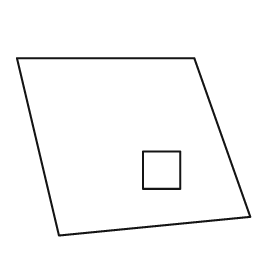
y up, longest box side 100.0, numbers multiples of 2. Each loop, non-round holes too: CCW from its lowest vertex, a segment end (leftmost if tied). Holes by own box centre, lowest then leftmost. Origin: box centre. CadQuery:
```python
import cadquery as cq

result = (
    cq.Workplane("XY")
    .moveTo(-32.0, -38.0)
    .lineTo(50.0, -30.0)
    .lineTo(26.0, 38.0)
    .lineTo(-50.0, 38.0)
    .close()
    .moveTo(4.0, -18.0)
    .lineTo(20.0, -18.0)
    .lineTo(20.0, -2.0)
    .lineTo(4.0, -2.0)
    .close()
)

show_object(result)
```